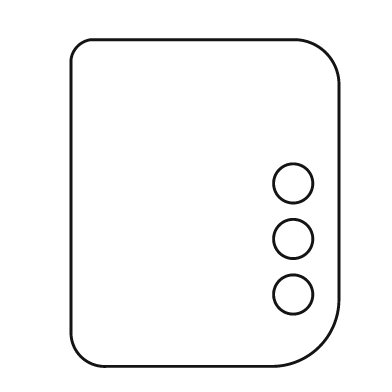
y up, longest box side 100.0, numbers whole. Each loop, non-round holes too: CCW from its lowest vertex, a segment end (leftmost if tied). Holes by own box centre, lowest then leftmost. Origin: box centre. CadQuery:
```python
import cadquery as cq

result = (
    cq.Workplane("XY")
    .moveTo(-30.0, -50.0)
    .lineTo(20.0, -50.0)
    .threePointArc((35.0, -44.0), (41.0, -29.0))
    .lineTo(41.0, 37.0)
    .threePointArc((37.0, 46.0), (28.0, 50.0))
    .lineTo(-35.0, 50.0)
    .threePointArc((-39.0, 48.0), (-41.0, 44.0))
    .lineTo(-41.0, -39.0)
    .threePointArc((-38.0, -47.0), (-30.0, -50.0))
    .close()
    .moveTo(27.0, -28.0)
    .circle(6.0)
    .moveTo(27.0, -11.0)
    .circle(6.0)
    .moveTo(27.0, 6.0)
    .circle(6.0)
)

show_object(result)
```